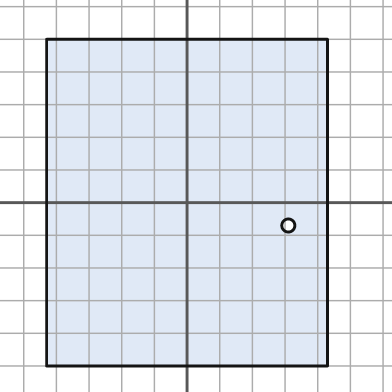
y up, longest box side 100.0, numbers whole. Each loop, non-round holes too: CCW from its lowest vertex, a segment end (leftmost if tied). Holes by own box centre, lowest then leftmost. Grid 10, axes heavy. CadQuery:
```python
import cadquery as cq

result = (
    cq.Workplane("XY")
    .moveTo(-43.0, -50.0)
    .lineTo(43.0, -50.0)
    .lineTo(43.0, 50.0)
    .lineTo(-43.0, 50.0)
    .close()
    .moveTo(31.0, -7.0)
    .circle(2.0)
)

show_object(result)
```